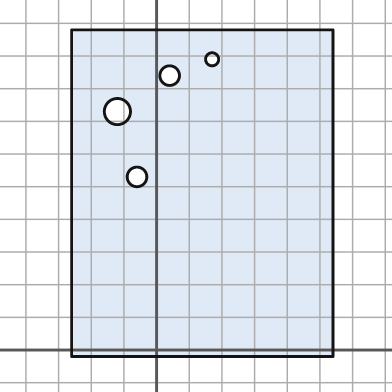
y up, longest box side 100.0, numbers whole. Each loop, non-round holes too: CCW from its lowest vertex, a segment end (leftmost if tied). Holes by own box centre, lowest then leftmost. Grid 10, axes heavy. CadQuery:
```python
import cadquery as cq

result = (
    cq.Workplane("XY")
    .moveTo(-26.0, -2.0)
    .lineTo(54.0, -2.0)
    .lineTo(54.0, 98.0)
    .lineTo(-26.0, 98.0)
    .close()
    .moveTo(-6.0, 53.0)
    .circle(3.0)
    .moveTo(-12.0, 73.0)
    .circle(4.0)
    .moveTo(4.0, 84.0)
    .circle(3.0)
    .moveTo(17.0, 89.0)
    .circle(2.0)
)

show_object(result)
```